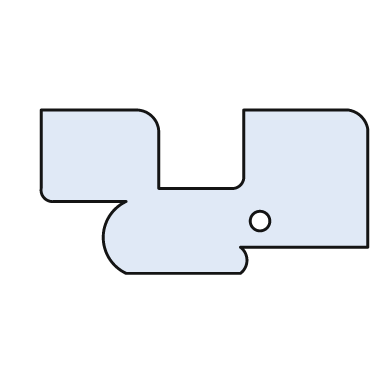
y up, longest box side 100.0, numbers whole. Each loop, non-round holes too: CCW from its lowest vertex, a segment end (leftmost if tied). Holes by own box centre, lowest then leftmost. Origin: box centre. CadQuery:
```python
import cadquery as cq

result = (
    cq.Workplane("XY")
    .moveTo(-24.0, -25.0)
    .lineTo(11.0, -25.0)
    .threePointArc((13.0, -21.0), (11.0, -17.0))
    .lineTo(50.0, -17.0)
    .lineTo(50.0, 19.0)
    .threePointArc((48.0, 23.0), (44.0, 25.0))
    .lineTo(12.0, 25.0)
    .lineTo(12.0, 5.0)
    .threePointArc((11.0, 2.0), (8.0, 1.0))
    .lineTo(-14.0, 1.0)
    .lineTo(-14.0, 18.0)
    .threePointArc((-16.0, 23.0), (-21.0, 25.0))
    .lineTo(-50.0, 25.0)
    .lineTo(-50.0, 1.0)
    .threePointArc((-49.0, -2.0), (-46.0, -3.0))
    .lineTo(-24.0, -3.0)
    .threePointArc((-31.0, -14.0), (-24.0, -25.0))
    .close()
    .moveTo(17.0, -9.0)
    .circle(3.0)
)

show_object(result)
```